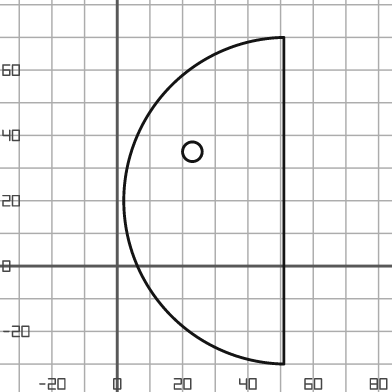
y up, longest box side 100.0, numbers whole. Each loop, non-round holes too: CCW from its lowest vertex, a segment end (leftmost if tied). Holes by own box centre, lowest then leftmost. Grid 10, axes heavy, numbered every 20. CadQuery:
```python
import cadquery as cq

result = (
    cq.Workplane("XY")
    .moveTo(51.0, -30.0)
    .lineTo(51.0, 70.0)
    .threePointArc((2.0, 20.0), (51.0, -30.0))
    .close()
    .moveTo(23.0, 35.0)
    .circle(3.0)
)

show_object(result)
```